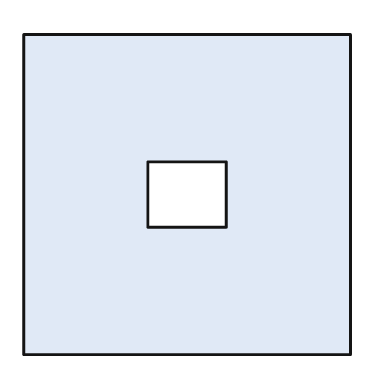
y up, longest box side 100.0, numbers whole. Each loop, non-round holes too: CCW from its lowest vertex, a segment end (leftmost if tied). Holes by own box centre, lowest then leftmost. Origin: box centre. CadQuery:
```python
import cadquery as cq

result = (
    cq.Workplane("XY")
    .moveTo(-50.0, -49.0)
    .lineTo(50.0, -49.0)
    .lineTo(50.0, 49.0)
    .lineTo(-50.0, 49.0)
    .close()
    .moveTo(-12.0, -10.0)
    .lineTo(12.0, -10.0)
    .lineTo(12.0, 10.0)
    .lineTo(-12.0, 10.0)
    .close()
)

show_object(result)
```